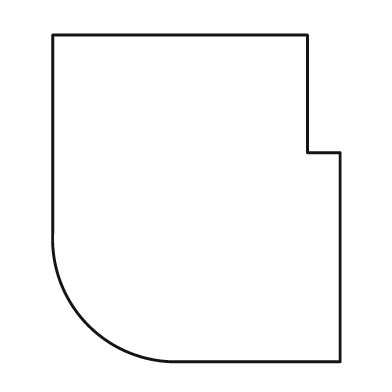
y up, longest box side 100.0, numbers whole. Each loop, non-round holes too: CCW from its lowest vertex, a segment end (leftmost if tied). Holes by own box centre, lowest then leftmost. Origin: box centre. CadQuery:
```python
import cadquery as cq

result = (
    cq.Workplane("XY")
    .moveTo(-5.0, -50.0)
    .lineTo(44.0, -50.0)
    .lineTo(44.0, 14.0)
    .lineTo(34.0, 14.0)
    .lineTo(34.0, 50.0)
    .lineTo(-44.0, 50.0)
    .lineTo(-44.0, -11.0)
    .threePointArc((-33.0, -39.0), (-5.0, -50.0))
    .close()
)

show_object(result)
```